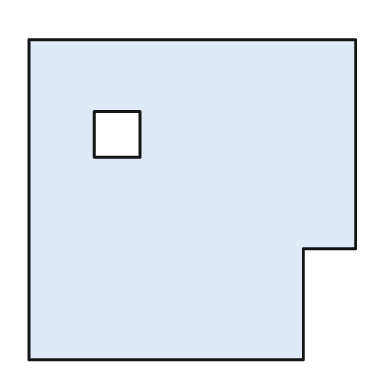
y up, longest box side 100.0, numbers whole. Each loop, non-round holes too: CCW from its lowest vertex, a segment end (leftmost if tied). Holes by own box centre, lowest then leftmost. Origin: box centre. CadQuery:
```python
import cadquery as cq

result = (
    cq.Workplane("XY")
    .moveTo(-50.0, -49.0)
    .lineTo(34.0, -49.0)
    .lineTo(34.0, -15.0)
    .lineTo(50.0, -15.0)
    .lineTo(50.0, 49.0)
    .lineTo(-50.0, 49.0)
    .close()
    .moveTo(-30.0, 13.0)
    .lineTo(-16.0, 13.0)
    .lineTo(-16.0, 27.0)
    .lineTo(-30.0, 27.0)
    .close()
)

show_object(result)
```